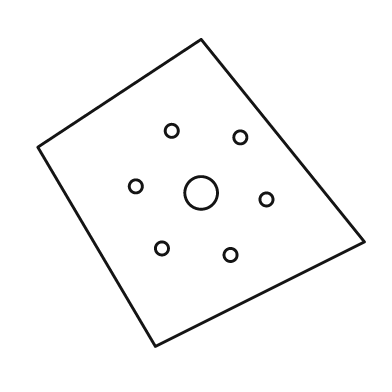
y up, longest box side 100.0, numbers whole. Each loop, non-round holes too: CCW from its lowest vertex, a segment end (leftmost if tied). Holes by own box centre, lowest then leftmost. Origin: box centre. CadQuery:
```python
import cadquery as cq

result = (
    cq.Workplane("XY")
    .moveTo(-14.0, -47.0)
    .lineTo(50.0, -15.0)
    .lineTo(0.0, 47.0)
    .lineTo(-50.0, 14.0)
    .close()
    .moveTo(9.0, -19.0)
    .circle(2.0)
    .moveTo(-12.0, -17.0)
    .circle(2.0)
    .moveTo(20.0, -2.0)
    .circle(2.0)
    .moveTo(0.0, 0.0)
    .circle(5.0)
    .moveTo(-20.0, 2.0)
    .circle(2.0)
    .moveTo(12.0, 17.0)
    .circle(2.0)
    .moveTo(-9.0, 19.0)
    .circle(2.0)
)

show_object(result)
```